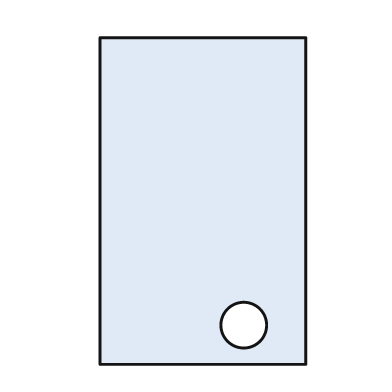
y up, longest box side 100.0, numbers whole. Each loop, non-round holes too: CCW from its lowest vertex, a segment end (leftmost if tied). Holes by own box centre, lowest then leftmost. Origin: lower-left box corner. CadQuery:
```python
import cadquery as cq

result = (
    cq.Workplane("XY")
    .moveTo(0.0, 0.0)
    .lineTo(63.0, 0.0)
    .lineTo(63.0, 100.0)
    .lineTo(0.0, 100.0)
    .close()
    .moveTo(44.0, 12.0)
    .circle(7.0)
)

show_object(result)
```